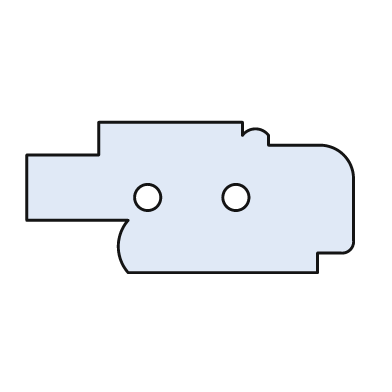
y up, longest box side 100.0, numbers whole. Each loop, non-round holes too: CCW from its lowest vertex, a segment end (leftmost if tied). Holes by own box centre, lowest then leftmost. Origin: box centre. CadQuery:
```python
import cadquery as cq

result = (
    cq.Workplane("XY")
    .moveTo(-19.0, -23.0)
    .lineTo(39.0, -23.0)
    .lineTo(39.0, -17.0)
    .lineTo(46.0, -17.0)
    .threePointArc((49.0, -16.0), (50.0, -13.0))
    .lineTo(50.0, 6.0)
    .threePointArc((47.0, 13.0), (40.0, 16.0))
    .lineTo(24.0, 16.0)
    .lineTo(24.0, 19.0)
    .threePointArc((20.0, 21.0), (16.0, 19.0))
    .lineTo(16.0, 23.0)
    .lineTo(-28.0, 23.0)
    .lineTo(-28.0, 13.0)
    .lineTo(-50.0, 13.0)
    .lineTo(-50.0, -7.0)
    .lineTo(-19.0, -7.0)
    .threePointArc((-22.0, -15.0), (-19.0, -23.0))
    .close()
    .moveTo(-13.0, 0.0)
    .circle(4.0)
    .moveTo(14.0, 0.0)
    .circle(4.0)
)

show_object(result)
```